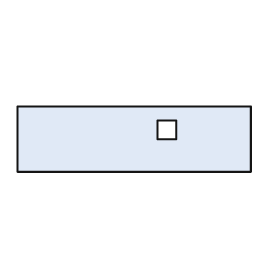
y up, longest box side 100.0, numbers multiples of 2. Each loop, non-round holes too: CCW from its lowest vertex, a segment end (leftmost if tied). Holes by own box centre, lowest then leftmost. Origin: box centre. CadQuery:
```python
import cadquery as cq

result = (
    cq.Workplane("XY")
    .moveTo(-50.0, -14.0)
    .lineTo(50.0, -14.0)
    .lineTo(50.0, 14.0)
    .lineTo(-50.0, 14.0)
    .close()
    .moveTo(10.0, 0.0)
    .lineTo(18.0, 0.0)
    .lineTo(18.0, 8.0)
    .lineTo(10.0, 8.0)
    .close()
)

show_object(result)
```